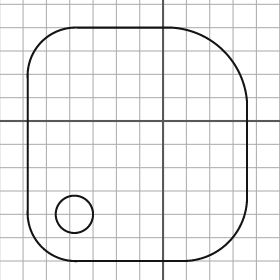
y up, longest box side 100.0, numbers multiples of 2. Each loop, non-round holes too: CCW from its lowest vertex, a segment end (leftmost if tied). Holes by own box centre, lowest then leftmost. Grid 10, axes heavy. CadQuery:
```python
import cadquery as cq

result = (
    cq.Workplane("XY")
    .moveTo(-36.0, -60.0)
    .lineTo(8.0, -60.0)
    .threePointArc((28.0, -52.0), (36.0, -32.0))
    .lineTo(36.0, 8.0)
    .threePointArc((26.0, 30.0), (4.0, 40.0))
    .lineTo(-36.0, 40.0)
    .threePointArc((-52.0, 34.0), (-58.0, 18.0))
    .lineTo(-58.0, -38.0)
    .threePointArc((-52.0, -54.0), (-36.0, -60.0))
    .close()
    .moveTo(-38.0, -40.0)
    .circle(8.0)
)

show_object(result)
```